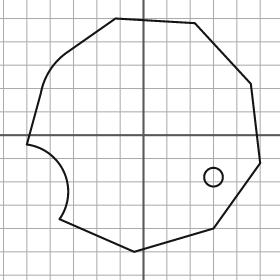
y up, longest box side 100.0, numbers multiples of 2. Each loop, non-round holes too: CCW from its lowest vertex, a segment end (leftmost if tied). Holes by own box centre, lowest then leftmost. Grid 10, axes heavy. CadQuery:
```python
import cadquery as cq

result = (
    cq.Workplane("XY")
    .moveTo(-4.0, -50.0)
    .lineTo(30.0, -40.0)
    .lineTo(50.0, -12.0)
    .lineTo(46.0, 22.0)
    .lineTo(22.0, 48.0)
    .lineTo(-12.0, 50.0)
    .lineTo(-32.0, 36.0)
    .threePointArc((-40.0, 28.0), (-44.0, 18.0))
    .lineTo(-50.0, -4.0)
    .threePointArc((-34.0, -16.0), (-36.0, -36.0))
    .close()
    .moveTo(30.0, -18.0)
    .circle(4.0)
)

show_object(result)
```